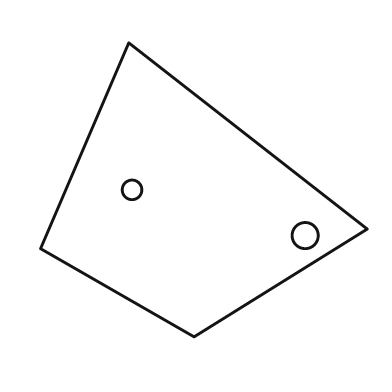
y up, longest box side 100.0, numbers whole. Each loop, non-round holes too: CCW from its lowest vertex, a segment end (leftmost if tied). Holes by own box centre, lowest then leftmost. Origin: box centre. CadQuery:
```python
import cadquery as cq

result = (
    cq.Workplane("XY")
    .moveTo(-3.0, -45.0)
    .lineTo(50.0, -12.0)
    .lineTo(-23.0, 45.0)
    .lineTo(-50.0, -18.0)
    .close()
    .moveTo(31.0, -14.0)
    .circle(4.0)
    .moveTo(-22.0, 0.0)
    .circle(3.0)
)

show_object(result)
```